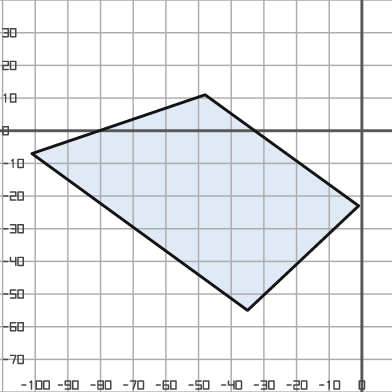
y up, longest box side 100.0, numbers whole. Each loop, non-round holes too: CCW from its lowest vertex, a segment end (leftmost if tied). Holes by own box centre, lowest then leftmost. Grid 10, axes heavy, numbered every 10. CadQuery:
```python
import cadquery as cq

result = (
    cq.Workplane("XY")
    .moveTo(-35.0, -55.0)
    .lineTo(-1.0, -23.0)
    .lineTo(-48.0, 11.0)
    .lineTo(-101.0, -7.0)
    .close()
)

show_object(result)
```